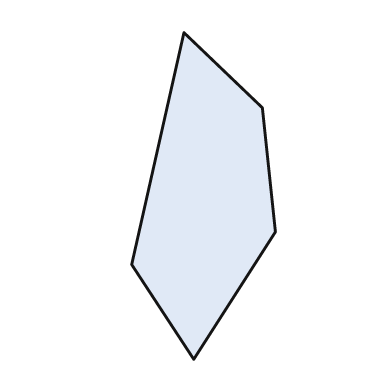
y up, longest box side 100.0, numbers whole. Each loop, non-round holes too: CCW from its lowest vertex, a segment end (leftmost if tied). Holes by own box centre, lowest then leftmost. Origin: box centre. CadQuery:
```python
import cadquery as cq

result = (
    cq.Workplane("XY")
    .moveTo(-3.0, -50.0)
    .lineTo(22.0, -11.0)
    .lineTo(18.0, 27.0)
    .lineTo(-6.0, 50.0)
    .lineTo(-22.0, -21.0)
    .close()
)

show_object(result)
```